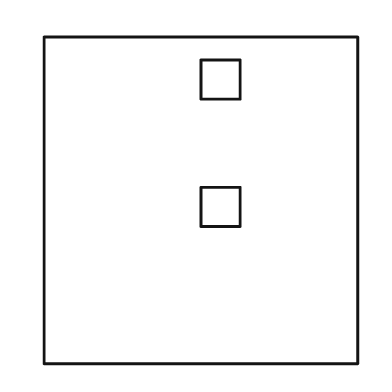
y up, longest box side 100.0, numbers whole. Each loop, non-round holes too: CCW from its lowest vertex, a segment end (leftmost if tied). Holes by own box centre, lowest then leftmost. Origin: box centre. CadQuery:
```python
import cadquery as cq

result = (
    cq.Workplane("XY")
    .moveTo(-48.0, -50.0)
    .lineTo(48.0, -50.0)
    .lineTo(48.0, 50.0)
    .lineTo(-48.0, 50.0)
    .close()
    .moveTo(0.0, -8.0)
    .lineTo(12.0, -8.0)
    .lineTo(12.0, 4.0)
    .lineTo(0.0, 4.0)
    .close()
    .moveTo(0.0, 31.0)
    .lineTo(12.0, 31.0)
    .lineTo(12.0, 43.0)
    .lineTo(0.0, 43.0)
    .close()
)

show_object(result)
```